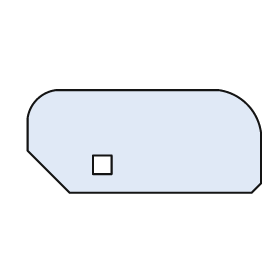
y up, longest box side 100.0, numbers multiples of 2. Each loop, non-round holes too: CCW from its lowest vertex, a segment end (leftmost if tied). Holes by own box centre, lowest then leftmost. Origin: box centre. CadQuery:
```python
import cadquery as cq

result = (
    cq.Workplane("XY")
    .moveTo(-32.0, -22.0)
    .lineTo(46.0, -22.0)
    .lineTo(50.0, -18.0)
    .lineTo(50.0, 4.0)
    .threePointArc((44.0, 16.0), (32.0, 22.0))
    .lineTo(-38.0, 22.0)
    .threePointArc((-46.0, 18.0), (-50.0, 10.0))
    .lineTo(-50.0, -4.0)
    .close()
    .moveTo(-22.0, -14.0)
    .lineTo(-14.0, -14.0)
    .lineTo(-14.0, -6.0)
    .lineTo(-22.0, -6.0)
    .close()
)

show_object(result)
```